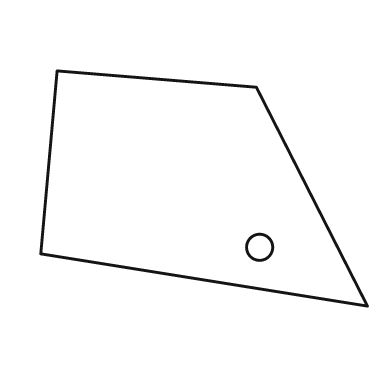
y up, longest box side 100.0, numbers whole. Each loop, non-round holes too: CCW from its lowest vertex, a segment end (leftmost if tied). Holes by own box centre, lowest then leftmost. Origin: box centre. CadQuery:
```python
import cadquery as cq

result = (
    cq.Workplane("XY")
    .moveTo(50.0, -36.0)
    .lineTo(16.0, 31.0)
    .lineTo(-45.0, 36.0)
    .lineTo(-50.0, -20.0)
    .close()
    .moveTo(17.0, -18.0)
    .circle(4.0)
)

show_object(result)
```